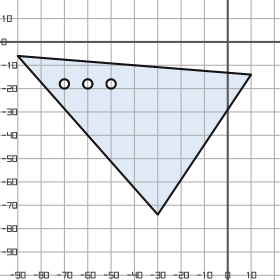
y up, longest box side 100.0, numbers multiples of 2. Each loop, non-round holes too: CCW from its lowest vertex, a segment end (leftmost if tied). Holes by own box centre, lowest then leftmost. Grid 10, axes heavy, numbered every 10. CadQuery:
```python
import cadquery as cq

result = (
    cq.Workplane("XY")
    .moveTo(-30.0, -74.0)
    .lineTo(10.0, -14.0)
    .lineTo(-90.0, -6.0)
    .close()
    .moveTo(-70.0, -18.0)
    .circle(2.0)
    .moveTo(-60.0, -18.0)
    .circle(2.0)
    .moveTo(-50.0, -18.0)
    .circle(2.0)
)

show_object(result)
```